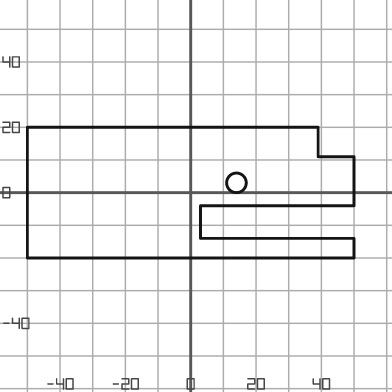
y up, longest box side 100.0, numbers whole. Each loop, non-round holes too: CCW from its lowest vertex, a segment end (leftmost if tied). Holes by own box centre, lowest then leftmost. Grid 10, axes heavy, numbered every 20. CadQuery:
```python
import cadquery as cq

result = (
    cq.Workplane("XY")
    .moveTo(-50.0, -20.0)
    .lineTo(50.0, -20.0)
    .lineTo(50.0, -14.0)
    .lineTo(3.0, -14.0)
    .lineTo(3.0, -4.0)
    .lineTo(50.0, -4.0)
    .lineTo(50.0, 11.0)
    .lineTo(39.0, 11.0)
    .lineTo(39.0, 20.0)
    .lineTo(-50.0, 20.0)
    .close()
    .moveTo(14.0, 3.0)
    .circle(3.0)
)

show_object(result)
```